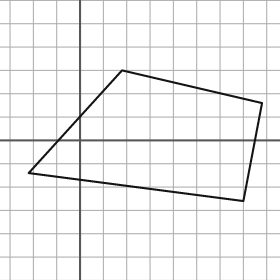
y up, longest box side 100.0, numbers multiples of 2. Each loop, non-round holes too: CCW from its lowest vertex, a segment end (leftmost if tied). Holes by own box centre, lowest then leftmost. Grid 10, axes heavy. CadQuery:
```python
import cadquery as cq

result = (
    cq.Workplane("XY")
    .moveTo(70.0, -26.0)
    .lineTo(78.0, 16.0)
    .lineTo(18.0, 30.0)
    .lineTo(-22.0, -14.0)
    .close()
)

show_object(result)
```